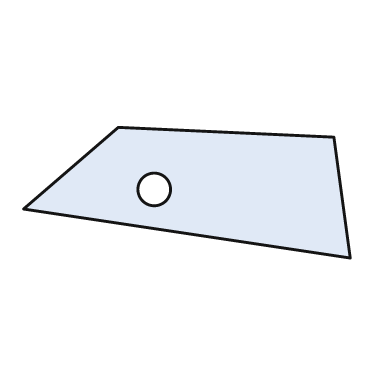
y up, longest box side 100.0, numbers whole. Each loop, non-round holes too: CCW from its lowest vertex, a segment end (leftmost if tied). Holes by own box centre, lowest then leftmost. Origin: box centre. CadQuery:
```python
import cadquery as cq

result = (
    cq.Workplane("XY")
    .moveTo(50.0, -20.0)
    .lineTo(45.0, 17.0)
    .lineTo(-21.0, 20.0)
    .lineTo(-50.0, -5.0)
    .close()
    .moveTo(-10.0, 1.0)
    .circle(5.0)
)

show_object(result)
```